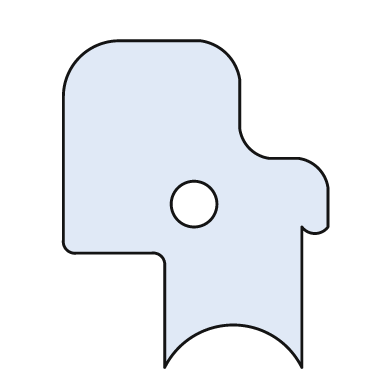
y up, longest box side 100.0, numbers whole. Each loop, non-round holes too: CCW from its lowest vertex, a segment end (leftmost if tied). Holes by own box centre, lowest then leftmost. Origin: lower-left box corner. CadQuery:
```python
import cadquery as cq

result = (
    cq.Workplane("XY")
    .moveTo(31.0, 0.0)
    .threePointArc((52.0, 13.0), (73.0, 0.0))
    .lineTo(73.0, 43.0)
    .threePointArc((77.0, 41.0), (81.0, 43.0))
    .lineTo(81.0, 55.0)
    .threePointArc((78.0, 61.0), (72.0, 64.0))
    .lineTo(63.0, 64.0)
    .threePointArc((57.0, 67.0), (54.0, 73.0))
    .lineTo(54.0, 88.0)
    .threePointArc((50.0, 96.0), (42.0, 100.0))
    .lineTo(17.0, 100.0)
    .threePointArc((5.0, 95.0), (0.0, 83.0))
    .lineTo(0.0, 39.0)
    .threePointArc((1.0, 36.0), (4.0, 35.0))
    .lineTo(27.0, 35.0)
    .threePointArc((30.0, 34.0), (31.0, 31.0))
    .close()
    .moveTo(40.0, 50.0)
    .circle(7.0)
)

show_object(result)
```